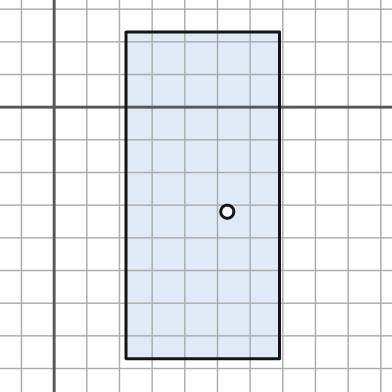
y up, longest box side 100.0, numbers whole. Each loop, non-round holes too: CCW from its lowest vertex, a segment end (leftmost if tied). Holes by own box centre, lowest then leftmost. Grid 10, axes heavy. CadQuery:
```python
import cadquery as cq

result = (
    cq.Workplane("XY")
    .moveTo(22.0, -77.0)
    .lineTo(69.0, -77.0)
    .lineTo(69.0, 23.0)
    .lineTo(22.0, 23.0)
    .close()
    .moveTo(53.0, -32.0)
    .circle(2.0)
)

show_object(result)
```